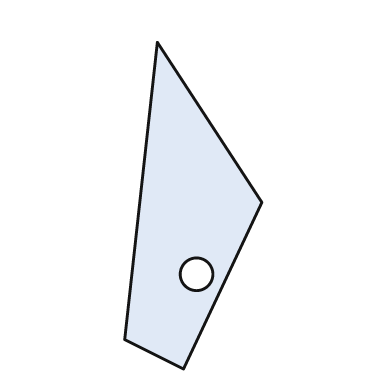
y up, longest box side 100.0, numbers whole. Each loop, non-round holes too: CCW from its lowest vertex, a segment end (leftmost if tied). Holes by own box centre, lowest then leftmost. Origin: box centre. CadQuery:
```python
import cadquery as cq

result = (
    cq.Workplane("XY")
    .moveTo(-3.0, -50.0)
    .lineTo(21.0, 1.0)
    .lineTo(-11.0, 50.0)
    .lineTo(-21.0, -41.0)
    .close()
    .moveTo(1.0, -21.0)
    .circle(5.0)
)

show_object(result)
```